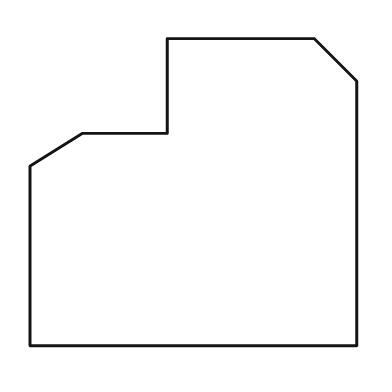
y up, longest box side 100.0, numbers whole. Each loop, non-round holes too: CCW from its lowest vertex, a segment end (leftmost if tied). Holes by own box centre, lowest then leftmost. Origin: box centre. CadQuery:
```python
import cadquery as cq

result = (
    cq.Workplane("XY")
    .moveTo(-50.0, -47.0)
    .lineTo(50.0, -47.0)
    .lineTo(50.0, 34.0)
    .lineTo(37.0, 47.0)
    .lineTo(-8.0, 47.0)
    .lineTo(-8.0, 18.0)
    .lineTo(-34.0, 18.0)
    .lineTo(-50.0, 8.0)
    .close()
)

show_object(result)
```